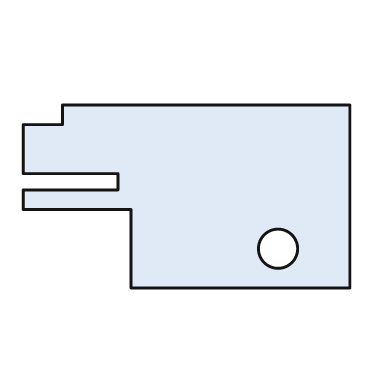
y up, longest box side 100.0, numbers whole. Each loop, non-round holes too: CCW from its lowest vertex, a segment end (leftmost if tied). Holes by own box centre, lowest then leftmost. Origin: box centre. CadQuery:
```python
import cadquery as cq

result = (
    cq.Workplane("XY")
    .moveTo(-17.0, -28.0)
    .lineTo(50.0, -28.0)
    .lineTo(50.0, 28.0)
    .lineTo(-38.0, 28.0)
    .lineTo(-38.0, 22.0)
    .lineTo(-50.0, 22.0)
    .lineTo(-50.0, 7.0)
    .lineTo(-21.0, 7.0)
    .lineTo(-21.0, 2.0)
    .lineTo(-50.0, 2.0)
    .lineTo(-50.0, -4.0)
    .lineTo(-17.0, -4.0)
    .close()
    .moveTo(28.0, -16.0)
    .circle(6.0)
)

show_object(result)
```